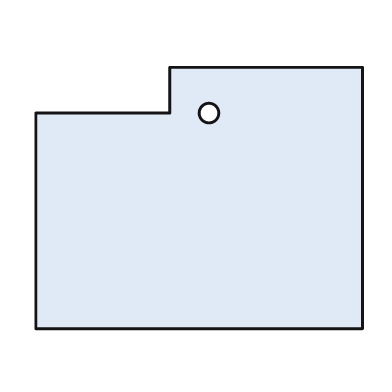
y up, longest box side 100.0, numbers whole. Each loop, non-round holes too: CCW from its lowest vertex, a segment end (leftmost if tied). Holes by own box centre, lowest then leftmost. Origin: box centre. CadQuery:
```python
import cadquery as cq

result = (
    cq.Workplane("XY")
    .moveTo(-50.0, -40.0)
    .lineTo(50.0, -40.0)
    .lineTo(50.0, 40.0)
    .lineTo(-9.0, 40.0)
    .lineTo(-9.0, 26.0)
    .lineTo(-50.0, 26.0)
    .close()
    .moveTo(3.0, 26.0)
    .circle(3.0)
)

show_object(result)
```